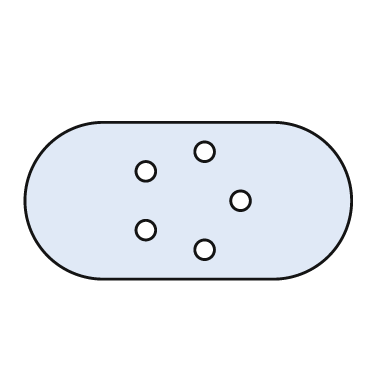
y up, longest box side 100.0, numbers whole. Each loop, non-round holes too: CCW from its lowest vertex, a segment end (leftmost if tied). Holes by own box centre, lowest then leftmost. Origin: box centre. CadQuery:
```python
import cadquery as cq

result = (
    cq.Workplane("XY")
    .moveTo(-26.0, -24.0)
    .lineTo(26.0, -24.0)
    .threePointArc((50.0, 0.0), (26.0, 24.0))
    .lineTo(-26.0, 24.0)
    .threePointArc((-50.0, 0.0), (-26.0, -24.0))
    .close()
    .moveTo(5.0, -15.0)
    .circle(3.0)
    .moveTo(-13.0, -9.0)
    .circle(3.0)
    .moveTo(16.0, 0.0)
    .circle(3.0)
    .moveTo(-13.0, 9.0)
    .circle(3.0)
    .moveTo(5.0, 15.0)
    .circle(3.0)
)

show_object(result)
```